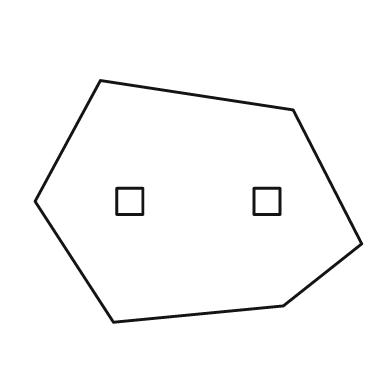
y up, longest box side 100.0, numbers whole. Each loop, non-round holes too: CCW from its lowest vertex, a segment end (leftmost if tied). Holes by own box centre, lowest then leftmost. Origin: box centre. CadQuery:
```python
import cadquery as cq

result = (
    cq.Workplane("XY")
    .moveTo(-26.0, -37.0)
    .lineTo(26.0, -32.0)
    .lineTo(50.0, -13.0)
    .lineTo(29.0, 28.0)
    .lineTo(-30.0, 37.0)
    .lineTo(-50.0, 0.0)
    .close()
    .moveTo(-25.0, -4.0)
    .lineTo(-17.0, -4.0)
    .lineTo(-17.0, 4.0)
    .lineTo(-25.0, 4.0)
    .close()
    .moveTo(17.0, -4.0)
    .lineTo(25.0, -4.0)
    .lineTo(25.0, 4.0)
    .lineTo(17.0, 4.0)
    .close()
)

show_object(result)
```